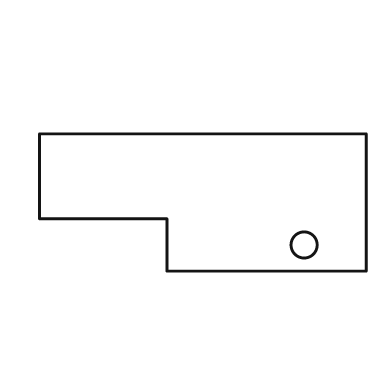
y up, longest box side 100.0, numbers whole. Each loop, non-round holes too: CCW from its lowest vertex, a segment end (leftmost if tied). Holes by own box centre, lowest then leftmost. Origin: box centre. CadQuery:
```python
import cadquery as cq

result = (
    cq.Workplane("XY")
    .moveTo(-11.0, -21.0)
    .lineTo(50.0, -21.0)
    .lineTo(50.0, 21.0)
    .lineTo(-50.0, 21.0)
    .lineTo(-50.0, -5.0)
    .lineTo(-11.0, -5.0)
    .close()
    .moveTo(31.0, -13.0)
    .circle(4.0)
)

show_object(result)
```